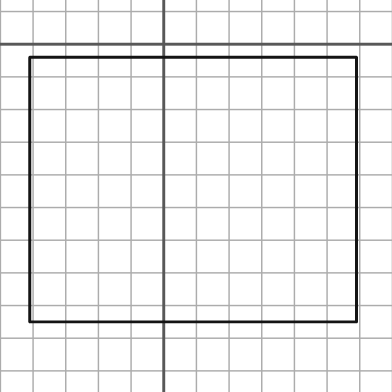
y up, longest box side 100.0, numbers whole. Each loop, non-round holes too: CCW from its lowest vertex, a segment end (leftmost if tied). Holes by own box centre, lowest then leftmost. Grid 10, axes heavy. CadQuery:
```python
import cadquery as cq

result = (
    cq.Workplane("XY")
    .moveTo(-41.0, -85.0)
    .lineTo(59.0, -85.0)
    .lineTo(59.0, -4.0)
    .lineTo(-41.0, -4.0)
    .close()
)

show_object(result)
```